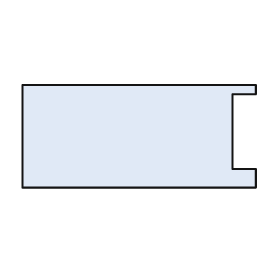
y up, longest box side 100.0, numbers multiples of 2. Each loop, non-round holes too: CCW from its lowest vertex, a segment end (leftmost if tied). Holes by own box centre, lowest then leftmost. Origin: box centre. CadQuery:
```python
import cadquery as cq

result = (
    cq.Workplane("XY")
    .moveTo(-50.0, -22.0)
    .lineTo(50.0, -22.0)
    .lineTo(50.0, -14.0)
    .lineTo(40.0, -14.0)
    .lineTo(40.0, 18.0)
    .lineTo(50.0, 18.0)
    .lineTo(50.0, 22.0)
    .lineTo(-50.0, 22.0)
    .close()
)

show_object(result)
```